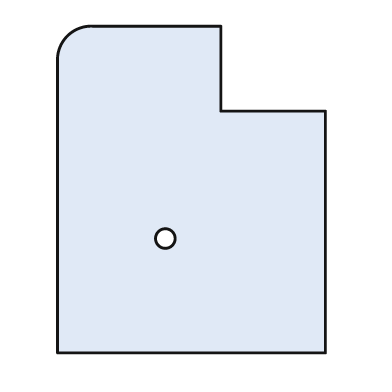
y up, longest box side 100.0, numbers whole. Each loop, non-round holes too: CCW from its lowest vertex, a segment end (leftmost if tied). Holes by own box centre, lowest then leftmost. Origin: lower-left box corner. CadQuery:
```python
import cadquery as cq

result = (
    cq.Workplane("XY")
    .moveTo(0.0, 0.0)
    .lineTo(82.0, 0.0)
    .lineTo(82.0, 74.0)
    .lineTo(50.0, 74.0)
    .lineTo(50.0, 100.0)
    .lineTo(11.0, 100.0)
    .threePointArc((3.0, 97.0), (0.0, 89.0))
    .close()
    .moveTo(33.0, 35.0)
    .circle(3.0)
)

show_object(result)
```